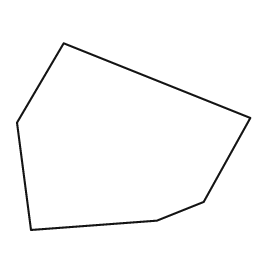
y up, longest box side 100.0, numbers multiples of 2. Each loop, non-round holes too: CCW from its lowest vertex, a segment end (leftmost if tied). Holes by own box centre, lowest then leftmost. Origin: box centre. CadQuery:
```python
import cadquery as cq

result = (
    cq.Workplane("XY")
    .moveTo(-44.0, -40.0)
    .lineTo(10.0, -36.0)
    .lineTo(30.0, -28.0)
    .lineTo(50.0, 8.0)
    .lineTo(-30.0, 40.0)
    .lineTo(-50.0, 6.0)
    .close()
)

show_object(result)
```